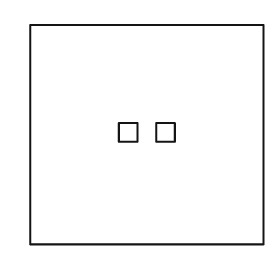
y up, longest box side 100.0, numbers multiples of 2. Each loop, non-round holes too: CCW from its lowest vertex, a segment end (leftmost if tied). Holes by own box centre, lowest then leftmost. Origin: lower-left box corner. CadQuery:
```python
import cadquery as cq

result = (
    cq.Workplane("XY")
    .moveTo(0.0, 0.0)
    .lineTo(100.0, 0.0)
    .lineTo(100.0, 94.0)
    .lineTo(0.0, 94.0)
    .close()
    .moveTo(38.0, 44.0)
    .lineTo(46.0, 44.0)
    .lineTo(46.0, 52.0)
    .lineTo(38.0, 52.0)
    .close()
    .moveTo(54.0, 44.0)
    .lineTo(62.0, 44.0)
    .lineTo(62.0, 52.0)
    .lineTo(54.0, 52.0)
    .close()
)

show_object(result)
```